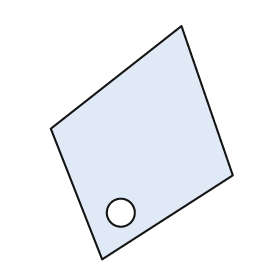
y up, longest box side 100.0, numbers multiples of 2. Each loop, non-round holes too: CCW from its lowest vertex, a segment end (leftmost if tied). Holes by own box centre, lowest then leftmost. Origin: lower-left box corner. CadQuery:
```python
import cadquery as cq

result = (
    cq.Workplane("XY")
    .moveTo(22.0, 0.0)
    .lineTo(78.0, 36.0)
    .lineTo(56.0, 100.0)
    .lineTo(0.0, 56.0)
    .close()
    .moveTo(30.0, 20.0)
    .circle(6.0)
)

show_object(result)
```